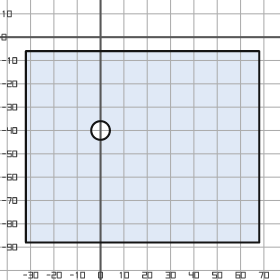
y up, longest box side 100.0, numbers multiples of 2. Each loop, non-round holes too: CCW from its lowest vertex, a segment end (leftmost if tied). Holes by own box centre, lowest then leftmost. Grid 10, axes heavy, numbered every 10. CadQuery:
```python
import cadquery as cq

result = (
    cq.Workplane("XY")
    .moveTo(-32.0, -88.0)
    .lineTo(68.0, -88.0)
    .lineTo(68.0, -6.0)
    .lineTo(-32.0, -6.0)
    .close()
    .moveTo(0.0, -40.0)
    .circle(4.0)
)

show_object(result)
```